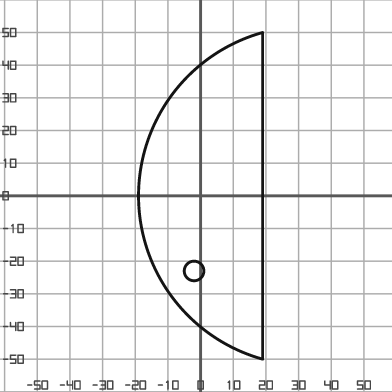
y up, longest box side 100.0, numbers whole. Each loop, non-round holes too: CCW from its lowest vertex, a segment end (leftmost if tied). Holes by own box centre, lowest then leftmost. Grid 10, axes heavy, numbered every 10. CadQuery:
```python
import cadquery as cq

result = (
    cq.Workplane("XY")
    .moveTo(19.0, -50.0)
    .lineTo(19.0, 50.0)
    .threePointArc((-19.0, 0.0), (19.0, -50.0))
    .close()
    .moveTo(-2.0, -23.0)
    .circle(3.0)
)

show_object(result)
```